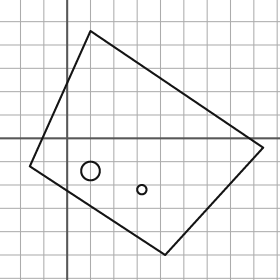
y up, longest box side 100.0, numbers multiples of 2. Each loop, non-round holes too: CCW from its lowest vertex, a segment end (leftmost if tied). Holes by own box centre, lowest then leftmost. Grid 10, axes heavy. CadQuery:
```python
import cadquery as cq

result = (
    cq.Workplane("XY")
    .moveTo(42.0, -50.0)
    .lineTo(84.0, -4.0)
    .lineTo(10.0, 46.0)
    .lineTo(-16.0, -12.0)
    .close()
    .moveTo(32.0, -22.0)
    .circle(2.0)
    .moveTo(10.0, -14.0)
    .circle(4.0)
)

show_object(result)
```